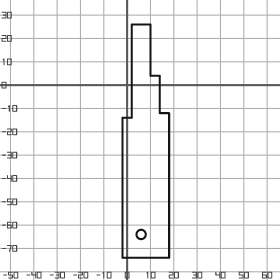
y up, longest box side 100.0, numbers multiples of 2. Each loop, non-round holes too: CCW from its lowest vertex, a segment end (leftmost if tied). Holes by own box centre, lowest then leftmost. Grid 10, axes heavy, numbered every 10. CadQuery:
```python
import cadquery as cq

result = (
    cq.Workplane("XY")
    .moveTo(-2.0, -74.0)
    .lineTo(18.0, -74.0)
    .lineTo(18.0, -12.0)
    .lineTo(14.0, -12.0)
    .lineTo(14.0, 4.0)
    .lineTo(10.0, 4.0)
    .lineTo(10.0, 26.0)
    .lineTo(2.0, 26.0)
    .lineTo(2.0, -14.0)
    .lineTo(-2.0, -14.0)
    .close()
    .moveTo(6.0, -64.0)
    .circle(2.0)
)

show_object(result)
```